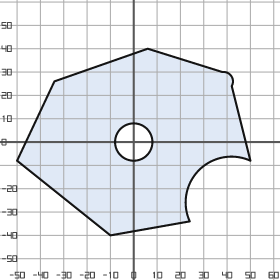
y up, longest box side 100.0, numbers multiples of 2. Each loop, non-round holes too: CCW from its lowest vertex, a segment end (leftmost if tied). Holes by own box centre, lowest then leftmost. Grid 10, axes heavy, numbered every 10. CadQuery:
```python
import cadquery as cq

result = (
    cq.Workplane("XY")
    .moveTo(-10.0, -40.0)
    .lineTo(24.0, -34.0)
    .threePointArc((28.0, -12.0), (50.0, -8.0))
    .lineTo(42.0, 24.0)
    .threePointArc((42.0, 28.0), (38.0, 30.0))
    .lineTo(6.0, 40.0)
    .lineTo(-34.0, 26.0)
    .lineTo(-50.0, -8.0)
    .close()
    .moveTo(0.0, 0.0)
    .circle(8.0)
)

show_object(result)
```